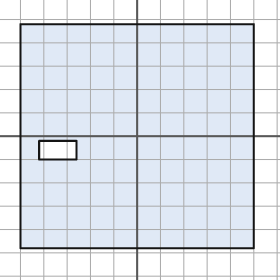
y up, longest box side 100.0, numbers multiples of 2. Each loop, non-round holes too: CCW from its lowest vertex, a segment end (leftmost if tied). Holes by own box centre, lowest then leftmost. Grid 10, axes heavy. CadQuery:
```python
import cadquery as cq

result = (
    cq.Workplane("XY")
    .moveTo(-50.0, -48.0)
    .lineTo(50.0, -48.0)
    .lineTo(50.0, 48.0)
    .lineTo(-50.0, 48.0)
    .close()
    .moveTo(-42.0, -10.0)
    .lineTo(-26.0, -10.0)
    .lineTo(-26.0, -2.0)
    .lineTo(-42.0, -2.0)
    .close()
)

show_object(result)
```